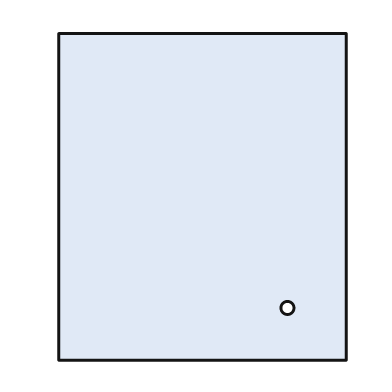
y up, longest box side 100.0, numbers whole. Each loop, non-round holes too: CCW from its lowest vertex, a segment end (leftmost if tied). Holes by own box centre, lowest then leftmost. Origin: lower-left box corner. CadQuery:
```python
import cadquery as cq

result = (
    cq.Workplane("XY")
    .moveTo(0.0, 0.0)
    .lineTo(88.0, 0.0)
    .lineTo(88.0, 100.0)
    .lineTo(0.0, 100.0)
    .close()
    .moveTo(70.0, 16.0)
    .circle(2.0)
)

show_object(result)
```